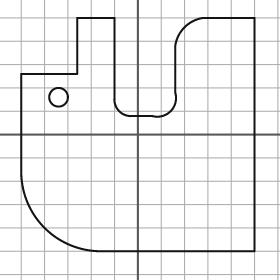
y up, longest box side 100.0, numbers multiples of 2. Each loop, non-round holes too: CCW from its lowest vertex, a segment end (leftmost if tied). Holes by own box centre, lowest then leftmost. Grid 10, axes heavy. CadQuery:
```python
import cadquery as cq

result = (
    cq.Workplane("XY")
    .moveTo(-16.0, -50.0)
    .lineTo(50.0, -50.0)
    .lineTo(50.0, 50.0)
    .lineTo(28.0, 50.0)
    .threePointArc((20.0, 46.0), (16.0, 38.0))
    .lineTo(16.0, 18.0)
    .threePointArc((14.0, 10.0), (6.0, 8.0))
    .lineTo(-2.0, 8.0)
    .threePointArc((-8.0, 10.0), (-10.0, 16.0))
    .lineTo(-10.0, 50.0)
    .lineTo(-26.0, 50.0)
    .lineTo(-26.0, 26.0)
    .lineTo(-50.0, 26.0)
    .lineTo(-50.0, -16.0)
    .threePointArc((-40.0, -40.0), (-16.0, -50.0))
    .close()
    .moveTo(-34.0, 16.0)
    .circle(4.0)
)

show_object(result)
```